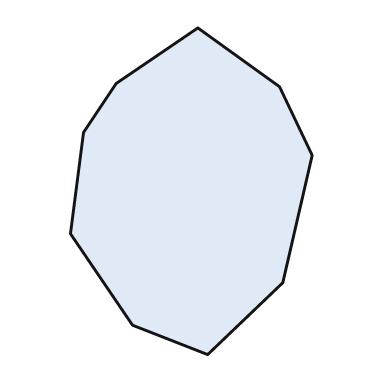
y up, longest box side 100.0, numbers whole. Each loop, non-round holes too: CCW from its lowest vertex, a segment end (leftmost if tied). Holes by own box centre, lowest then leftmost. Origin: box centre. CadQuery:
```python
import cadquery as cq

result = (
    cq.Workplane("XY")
    .moveTo(5.0, -50.0)
    .lineTo(28.0, -28.0)
    .lineTo(37.0, 11.0)
    .lineTo(27.0, 32.0)
    .lineTo(2.0, 50.0)
    .lineTo(-23.0, 33.0)
    .lineTo(-33.0, 18.0)
    .lineTo(-37.0, -13.0)
    .lineTo(-18.0, -41.0)
    .close()
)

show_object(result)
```